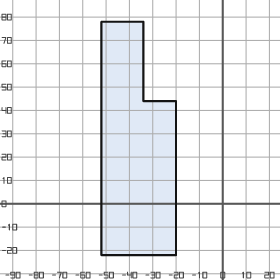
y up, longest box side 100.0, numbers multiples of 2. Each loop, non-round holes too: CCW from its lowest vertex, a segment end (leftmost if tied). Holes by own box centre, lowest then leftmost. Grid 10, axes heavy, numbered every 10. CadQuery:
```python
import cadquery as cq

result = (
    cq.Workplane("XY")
    .moveTo(-52.0, -22.0)
    .lineTo(-20.0, -22.0)
    .lineTo(-20.0, 44.0)
    .lineTo(-34.0, 44.0)
    .lineTo(-34.0, 78.0)
    .lineTo(-52.0, 78.0)
    .close()
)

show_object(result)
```